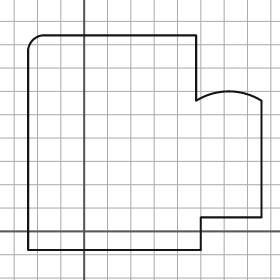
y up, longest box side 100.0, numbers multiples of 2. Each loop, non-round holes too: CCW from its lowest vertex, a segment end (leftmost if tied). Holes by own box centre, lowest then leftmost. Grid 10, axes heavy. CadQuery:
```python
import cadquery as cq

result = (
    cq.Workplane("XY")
    .moveTo(-24.0, -8.0)
    .lineTo(50.0, -8.0)
    .lineTo(50.0, 6.0)
    .lineTo(76.0, 6.0)
    .lineTo(76.0, 56.0)
    .threePointArc((62.0, 60.0), (48.0, 56.0))
    .lineTo(48.0, 84.0)
    .lineTo(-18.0, 84.0)
    .threePointArc((-22.0, 82.0), (-24.0, 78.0))
    .close()
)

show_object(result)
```